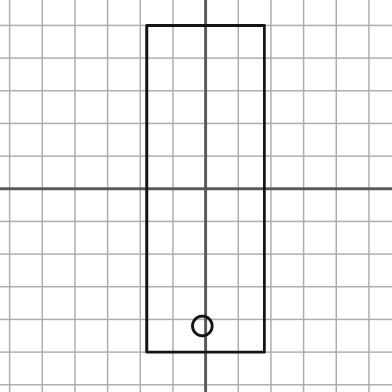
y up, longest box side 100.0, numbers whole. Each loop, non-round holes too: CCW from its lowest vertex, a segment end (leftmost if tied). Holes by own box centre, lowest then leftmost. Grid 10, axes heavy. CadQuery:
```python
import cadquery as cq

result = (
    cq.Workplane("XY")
    .moveTo(-18.0, -50.0)
    .lineTo(18.0, -50.0)
    .lineTo(18.0, 50.0)
    .lineTo(-18.0, 50.0)
    .close()
    .moveTo(-1.0, -42.0)
    .circle(3.0)
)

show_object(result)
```